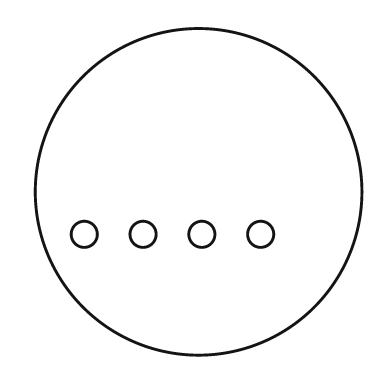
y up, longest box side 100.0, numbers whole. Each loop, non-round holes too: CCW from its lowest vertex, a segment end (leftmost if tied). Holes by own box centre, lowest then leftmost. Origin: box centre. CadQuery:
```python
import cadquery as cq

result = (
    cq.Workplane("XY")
    .moveTo(0.0, 0.0)
    .circle(50.0)
    .moveTo(-35.0, -13.0)
    .circle(4.0)
    .moveTo(-17.0, -13.0)
    .circle(4.0)
    .moveTo(1.0, -13.0)
    .circle(4.0)
    .moveTo(19.0, -13.0)
    .circle(4.0)
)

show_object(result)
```